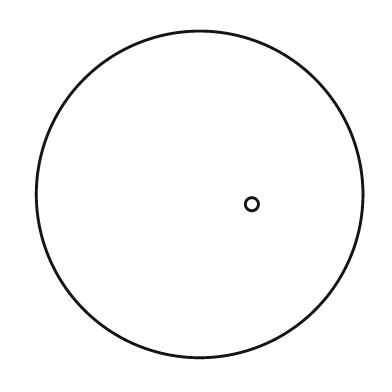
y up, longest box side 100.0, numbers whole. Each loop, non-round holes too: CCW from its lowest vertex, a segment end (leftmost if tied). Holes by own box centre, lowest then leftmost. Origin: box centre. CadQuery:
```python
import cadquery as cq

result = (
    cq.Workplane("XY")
    .moveTo(0.0, 0.0)
    .circle(50.0)
    .moveTo(16.0, -3.0)
    .circle(2.0)
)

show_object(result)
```